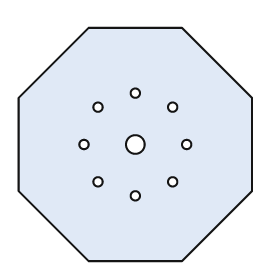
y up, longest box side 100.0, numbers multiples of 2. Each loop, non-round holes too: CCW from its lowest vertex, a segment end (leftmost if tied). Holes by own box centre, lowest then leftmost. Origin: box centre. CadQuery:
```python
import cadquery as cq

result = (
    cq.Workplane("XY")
    .moveTo(-20.0, -50.0)
    .lineTo(20.0, -50.0)
    .lineTo(50.0, -20.0)
    .lineTo(50.0, 20.0)
    .lineTo(20.0, 50.0)
    .lineTo(-20.0, 50.0)
    .lineTo(-50.0, 20.0)
    .lineTo(-50.0, -20.0)
    .close()
    .moveTo(0.0, -22.0)
    .circle(2.0)
    .moveTo(-16.0, -16.0)
    .circle(2.0)
    .moveTo(16.0, -16.0)
    .circle(2.0)
    .moveTo(-22.0, 0.0)
    .circle(2.0)
    .moveTo(0.0, 0.0)
    .circle(4.0)
    .moveTo(22.0, 0.0)
    .circle(2.0)
    .moveTo(-16.0, 16.0)
    .circle(2.0)
    .moveTo(16.0, 16.0)
    .circle(2.0)
    .moveTo(0.0, 22.0)
    .circle(2.0)
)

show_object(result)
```